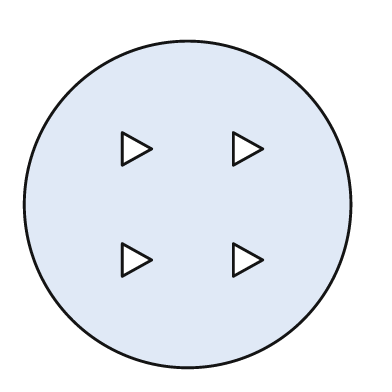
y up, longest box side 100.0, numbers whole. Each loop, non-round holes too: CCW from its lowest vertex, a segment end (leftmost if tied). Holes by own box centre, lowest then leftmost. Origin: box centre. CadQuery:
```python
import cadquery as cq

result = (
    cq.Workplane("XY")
    .moveTo(0.0, 0.0)
    .circle(50.0)
    .moveTo(-20.0, -22.0)
    .lineTo(-11.0, -17.0)
    .lineTo(-20.0, -12.0)
    .close()
    .moveTo(14.0, -22.0)
    .lineTo(23.0, -17.0)
    .lineTo(14.0, -12.0)
    .close()
    .moveTo(-20.0, 12.0)
    .lineTo(-11.0, 17.0)
    .lineTo(-20.0, 22.0)
    .close()
    .moveTo(14.0, 12.0)
    .lineTo(23.0, 17.0)
    .lineTo(14.0, 22.0)
    .close()
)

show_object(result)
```